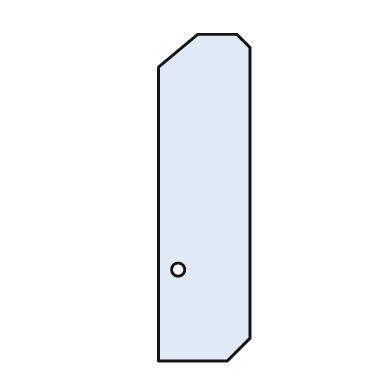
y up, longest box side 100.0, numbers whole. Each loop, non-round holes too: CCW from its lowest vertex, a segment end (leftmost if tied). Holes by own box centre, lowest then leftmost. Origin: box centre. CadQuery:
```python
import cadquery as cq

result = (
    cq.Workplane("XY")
    .moveTo(-14.0, -50.0)
    .lineTo(7.0, -50.0)
    .lineTo(14.0, -43.0)
    .lineTo(14.0, 46.0)
    .lineTo(10.0, 50.0)
    .lineTo(-2.0, 50.0)
    .lineTo(-14.0, 40.0)
    .close()
    .moveTo(-8.0, -22.0)
    .circle(2.0)
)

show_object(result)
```